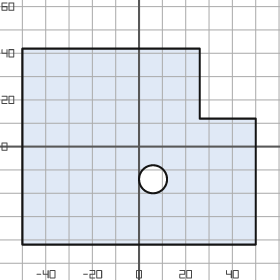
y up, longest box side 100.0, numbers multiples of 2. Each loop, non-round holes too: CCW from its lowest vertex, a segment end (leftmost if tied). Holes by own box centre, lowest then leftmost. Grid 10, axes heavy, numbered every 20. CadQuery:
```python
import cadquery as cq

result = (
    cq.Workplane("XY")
    .moveTo(-50.0, -42.0)
    .lineTo(50.0, -42.0)
    .lineTo(50.0, 12.0)
    .lineTo(26.0, 12.0)
    .lineTo(26.0, 42.0)
    .lineTo(-50.0, 42.0)
    .close()
    .moveTo(6.0, -14.0)
    .circle(6.0)
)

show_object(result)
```